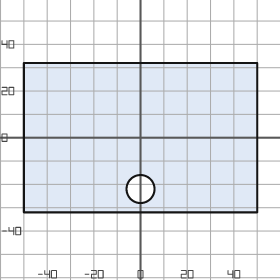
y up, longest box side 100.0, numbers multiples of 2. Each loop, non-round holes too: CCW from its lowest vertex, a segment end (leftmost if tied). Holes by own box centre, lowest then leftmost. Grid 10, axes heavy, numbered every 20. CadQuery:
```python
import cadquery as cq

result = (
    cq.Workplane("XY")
    .moveTo(-50.0, -32.0)
    .lineTo(50.0, -32.0)
    .lineTo(50.0, 32.0)
    .lineTo(-50.0, 32.0)
    .close()
    .moveTo(0.0, -22.0)
    .circle(6.0)
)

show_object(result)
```